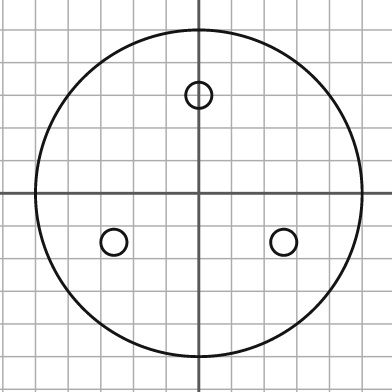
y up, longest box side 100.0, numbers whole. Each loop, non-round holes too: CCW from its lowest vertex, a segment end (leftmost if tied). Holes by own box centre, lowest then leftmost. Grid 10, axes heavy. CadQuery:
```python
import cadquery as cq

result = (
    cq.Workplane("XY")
    .moveTo(0.0, 0.0)
    .circle(50.0)
    .moveTo(-26.0, -15.0)
    .circle(4.0)
    .moveTo(26.0, -15.0)
    .circle(4.0)
    .moveTo(0.0, 30.0)
    .circle(4.0)
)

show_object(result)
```